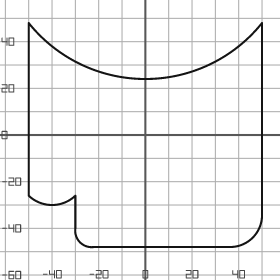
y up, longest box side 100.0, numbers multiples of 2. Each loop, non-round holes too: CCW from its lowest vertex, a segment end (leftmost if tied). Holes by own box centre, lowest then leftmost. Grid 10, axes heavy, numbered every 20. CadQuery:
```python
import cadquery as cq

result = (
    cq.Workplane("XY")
    .moveTo(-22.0, -48.0)
    .lineTo(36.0, -48.0)
    .threePointArc((46.0, -44.0), (50.0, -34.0))
    .lineTo(50.0, 48.0)
    .threePointArc((0.0, 24.0), (-50.0, 48.0))
    .lineTo(-50.0, -26.0)
    .threePointArc((-40.0, -30.0), (-30.0, -26.0))
    .lineTo(-30.0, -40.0)
    .threePointArc((-28.0, -46.0), (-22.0, -48.0))
    .close()
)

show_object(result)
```